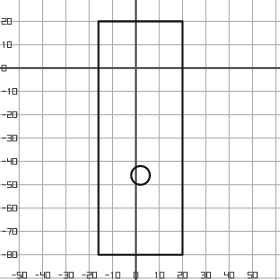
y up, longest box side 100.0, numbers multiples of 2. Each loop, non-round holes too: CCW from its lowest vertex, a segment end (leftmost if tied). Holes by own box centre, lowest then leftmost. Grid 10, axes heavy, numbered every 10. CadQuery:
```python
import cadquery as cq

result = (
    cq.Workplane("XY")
    .moveTo(-16.0, -80.0)
    .lineTo(20.0, -80.0)
    .lineTo(20.0, 20.0)
    .lineTo(-16.0, 20.0)
    .close()
    .moveTo(2.0, -46.0)
    .circle(4.0)
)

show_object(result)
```